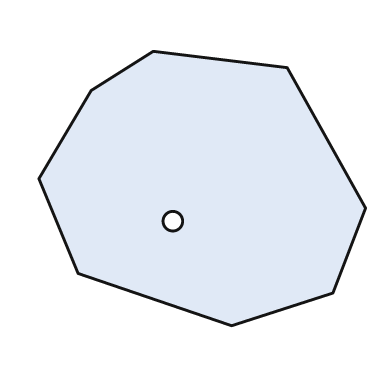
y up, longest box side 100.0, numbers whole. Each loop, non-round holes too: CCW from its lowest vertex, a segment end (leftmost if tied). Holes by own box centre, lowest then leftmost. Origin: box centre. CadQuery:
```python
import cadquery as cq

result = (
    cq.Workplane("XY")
    .moveTo(9.0, -42.0)
    .lineTo(40.0, -32.0)
    .lineTo(50.0, -6.0)
    .lineTo(26.0, 37.0)
    .lineTo(-15.0, 42.0)
    .lineTo(-34.0, 30.0)
    .lineTo(-50.0, 3.0)
    .lineTo(-38.0, -26.0)
    .close()
    .moveTo(-9.0, -10.0)
    .circle(3.0)
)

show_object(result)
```